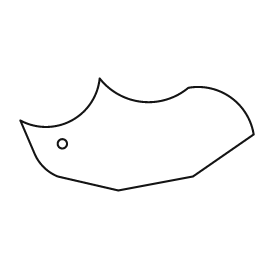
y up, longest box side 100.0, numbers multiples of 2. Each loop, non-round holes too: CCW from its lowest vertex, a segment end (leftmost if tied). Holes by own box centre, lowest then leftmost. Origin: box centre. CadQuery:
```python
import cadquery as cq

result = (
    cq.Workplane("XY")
    .moveTo(-8.0, -24.0)
    .lineTo(24.0, -18.0)
    .lineTo(50.0, 0.0)
    .threePointArc((40.0, 16.0), (22.0, 20.0))
    .threePointArc((2.0, 14.0), (-16.0, 24.0))
    .threePointArc((-28.0, 6.0), (-50.0, 6.0))
    .lineTo(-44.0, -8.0)
    .threePointArc((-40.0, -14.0), (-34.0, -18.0))
    .close()
    .moveTo(-32.0, -4.0)
    .circle(2.0)
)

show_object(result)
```